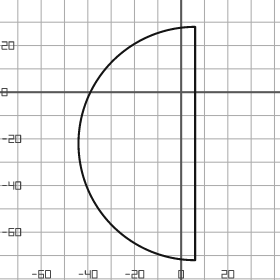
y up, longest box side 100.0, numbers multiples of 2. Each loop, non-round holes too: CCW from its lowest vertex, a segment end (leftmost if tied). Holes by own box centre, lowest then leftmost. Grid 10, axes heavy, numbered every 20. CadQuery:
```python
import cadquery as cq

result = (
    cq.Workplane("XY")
    .moveTo(6.0, -72.0)
    .lineTo(6.0, 28.0)
    .threePointArc((-44.0, -22.0), (6.0, -72.0))
    .close()
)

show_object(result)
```